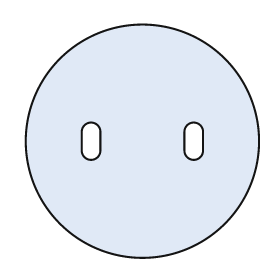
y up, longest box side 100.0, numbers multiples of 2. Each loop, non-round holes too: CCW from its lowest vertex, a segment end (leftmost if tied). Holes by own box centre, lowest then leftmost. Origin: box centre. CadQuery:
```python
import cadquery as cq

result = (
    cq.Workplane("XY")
    .moveTo(0.0, 0.0)
    .circle(50.0)
    .moveTo(-26.0, -4.0)
    .threePointArc((-22.0, -8.0), (-18.0, -4.0))
    .lineTo(-18.0, 4.0)
    .threePointArc((-22.0, 8.0), (-26.0, 4.0))
    .close()
    .moveTo(18.0, -4.0)
    .threePointArc((22.0, -8.0), (26.0, -4.0))
    .lineTo(26.0, 4.0)
    .threePointArc((22.0, 8.0), (18.0, 4.0))
    .close()
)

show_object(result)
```